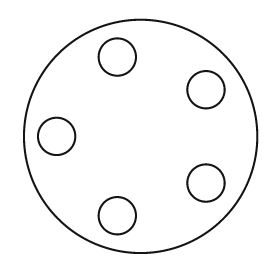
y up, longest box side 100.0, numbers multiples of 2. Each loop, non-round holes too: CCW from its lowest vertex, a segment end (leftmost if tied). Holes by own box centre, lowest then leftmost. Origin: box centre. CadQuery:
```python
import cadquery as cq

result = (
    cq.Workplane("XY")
    .moveTo(0.0, 0.0)
    .circle(50.0)
    .moveTo(-10.0, -34.0)
    .circle(8.0)
    .moveTo(28.0, -20.0)
    .circle(8.0)
    .moveTo(-36.0, 0.0)
    .circle(8.0)
    .moveTo(28.0, 20.0)
    .circle(8.0)
    .moveTo(-10.0, 34.0)
    .circle(8.0)
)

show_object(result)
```